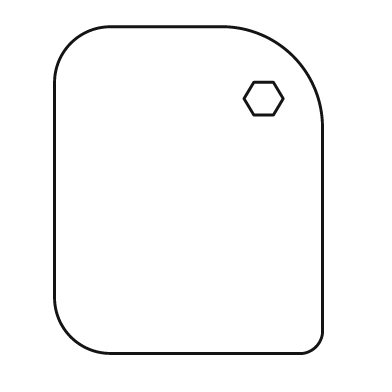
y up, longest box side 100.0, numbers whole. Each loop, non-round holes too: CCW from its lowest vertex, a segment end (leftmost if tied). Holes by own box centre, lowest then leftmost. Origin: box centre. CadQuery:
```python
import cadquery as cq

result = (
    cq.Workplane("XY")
    .moveTo(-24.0, -50.0)
    .lineTo(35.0, -50.0)
    .threePointArc((39.0, -48.0), (41.0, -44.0))
    .lineTo(41.0, 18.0)
    .threePointArc((32.0, 41.0), (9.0, 50.0))
    .lineTo(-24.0, 50.0)
    .threePointArc((-36.0, 45.0), (-41.0, 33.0))
    .lineTo(-41.0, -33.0)
    .threePointArc((-36.0, -45.0), (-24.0, -50.0))
    .close()
    .moveTo(20.0, 23.0)
    .lineTo(26.0, 23.0)
    .lineTo(29.0, 28.0)
    .lineTo(26.0, 33.0)
    .lineTo(20.0, 33.0)
    .lineTo(17.0, 28.0)
    .close()
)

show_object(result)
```